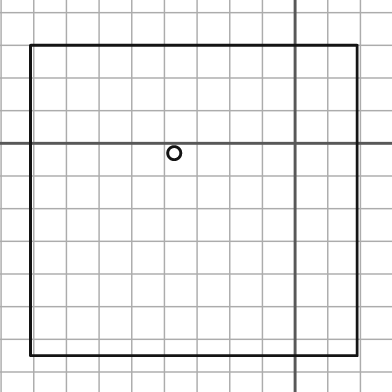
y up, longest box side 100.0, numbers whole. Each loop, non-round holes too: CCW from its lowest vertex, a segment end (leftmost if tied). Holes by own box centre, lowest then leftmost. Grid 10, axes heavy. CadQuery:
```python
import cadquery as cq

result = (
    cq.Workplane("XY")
    .moveTo(-81.0, -65.0)
    .lineTo(19.0, -65.0)
    .lineTo(19.0, 30.0)
    .lineTo(-81.0, 30.0)
    .close()
    .moveTo(-37.0, -3.0)
    .circle(2.0)
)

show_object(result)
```